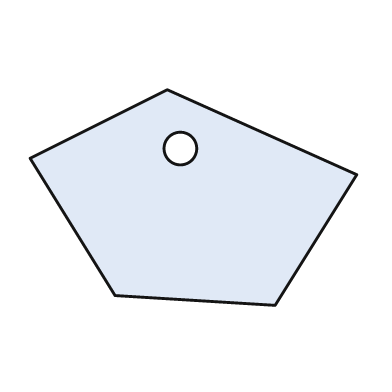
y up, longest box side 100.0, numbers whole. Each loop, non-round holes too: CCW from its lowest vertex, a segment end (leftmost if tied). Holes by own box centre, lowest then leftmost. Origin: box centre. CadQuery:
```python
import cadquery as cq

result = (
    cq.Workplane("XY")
    .moveTo(25.0, -33.0)
    .lineTo(50.0, 7.0)
    .lineTo(-8.0, 33.0)
    .lineTo(-50.0, 12.0)
    .lineTo(-24.0, -30.0)
    .close()
    .moveTo(-4.0, 15.0)
    .circle(5.0)
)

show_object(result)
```